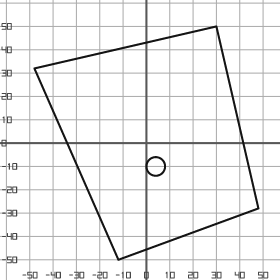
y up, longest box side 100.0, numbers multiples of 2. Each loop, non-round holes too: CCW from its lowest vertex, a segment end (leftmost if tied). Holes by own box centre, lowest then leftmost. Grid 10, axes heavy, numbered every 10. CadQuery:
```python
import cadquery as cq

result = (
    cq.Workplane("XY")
    .moveTo(-12.0, -50.0)
    .lineTo(48.0, -28.0)
    .lineTo(30.0, 50.0)
    .lineTo(-48.0, 32.0)
    .close()
    .moveTo(4.0, -10.0)
    .circle(4.0)
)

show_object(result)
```